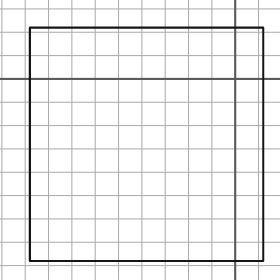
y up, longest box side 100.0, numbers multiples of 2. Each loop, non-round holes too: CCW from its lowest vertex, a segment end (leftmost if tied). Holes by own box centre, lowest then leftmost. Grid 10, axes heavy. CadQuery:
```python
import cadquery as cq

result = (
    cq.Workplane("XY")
    .moveTo(-88.0, -78.0)
    .lineTo(12.0, -78.0)
    .lineTo(12.0, 22.0)
    .lineTo(-88.0, 22.0)
    .close()
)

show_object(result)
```